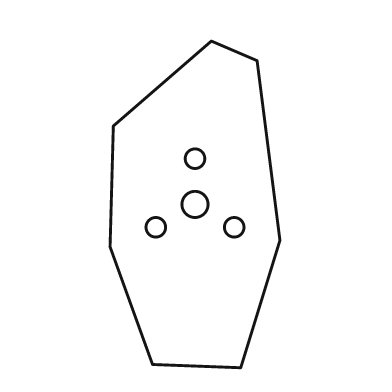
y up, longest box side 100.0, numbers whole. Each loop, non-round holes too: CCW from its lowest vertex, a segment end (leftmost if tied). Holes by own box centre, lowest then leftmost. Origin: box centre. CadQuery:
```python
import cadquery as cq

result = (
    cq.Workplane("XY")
    .moveTo(14.0, -50.0)
    .lineTo(26.0, -11.0)
    .lineTo(19.0, 44.0)
    .lineTo(5.0, 50.0)
    .lineTo(-25.0, 24.0)
    .lineTo(-26.0, -13.0)
    .lineTo(-13.0, -49.0)
    .close()
    .moveTo(-12.0, -7.0)
    .circle(3.0)
    .moveTo(12.0, -7.0)
    .circle(3.0)
    .moveTo(0.0, 0.0)
    .circle(4.0)
    .moveTo(0.0, 14.0)
    .circle(3.0)
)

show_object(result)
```